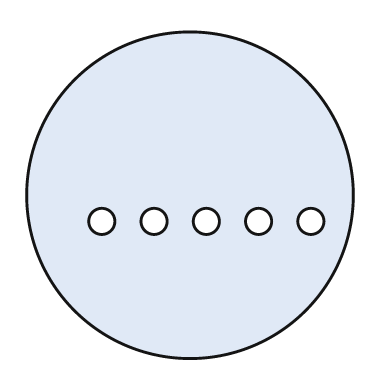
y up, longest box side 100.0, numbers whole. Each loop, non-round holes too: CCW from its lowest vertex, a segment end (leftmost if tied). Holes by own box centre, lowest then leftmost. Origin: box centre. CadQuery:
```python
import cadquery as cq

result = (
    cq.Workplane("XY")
    .moveTo(0.0, 0.0)
    .circle(50.0)
    .moveTo(-27.0, -8.0)
    .circle(4.0)
    .moveTo(-11.0, -8.0)
    .circle(4.0)
    .moveTo(5.0, -8.0)
    .circle(4.0)
    .moveTo(21.0, -8.0)
    .circle(4.0)
    .moveTo(37.0, -8.0)
    .circle(4.0)
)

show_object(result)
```